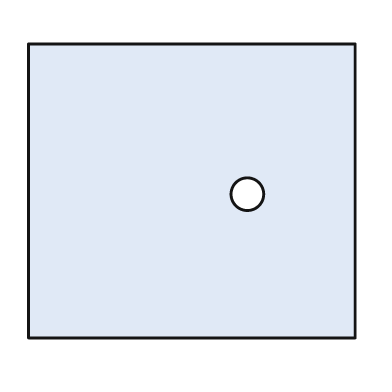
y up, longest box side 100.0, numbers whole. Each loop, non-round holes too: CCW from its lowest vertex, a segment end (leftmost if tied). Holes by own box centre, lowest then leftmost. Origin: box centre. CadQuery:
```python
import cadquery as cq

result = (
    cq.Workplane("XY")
    .moveTo(-50.0, -45.0)
    .lineTo(50.0, -45.0)
    .lineTo(50.0, 45.0)
    .lineTo(-50.0, 45.0)
    .close()
    .moveTo(17.0, -1.0)
    .circle(5.0)
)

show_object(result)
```